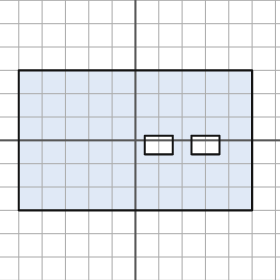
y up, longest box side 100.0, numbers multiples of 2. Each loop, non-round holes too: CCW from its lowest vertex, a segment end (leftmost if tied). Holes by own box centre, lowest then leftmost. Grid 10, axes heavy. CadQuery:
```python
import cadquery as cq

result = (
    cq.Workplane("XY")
    .moveTo(-50.0, -30.0)
    .lineTo(50.0, -30.0)
    .lineTo(50.0, 30.0)
    .lineTo(-50.0, 30.0)
    .close()
    .moveTo(4.0, -6.0)
    .lineTo(16.0, -6.0)
    .lineTo(16.0, 2.0)
    .lineTo(4.0, 2.0)
    .close()
    .moveTo(24.0, -6.0)
    .lineTo(36.0, -6.0)
    .lineTo(36.0, 2.0)
    .lineTo(24.0, 2.0)
    .close()
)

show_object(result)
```